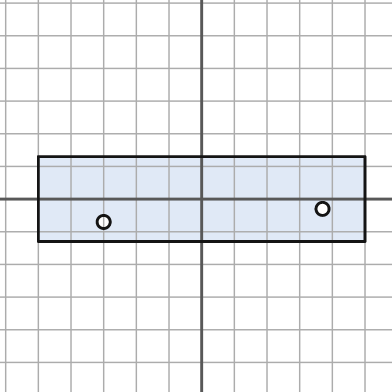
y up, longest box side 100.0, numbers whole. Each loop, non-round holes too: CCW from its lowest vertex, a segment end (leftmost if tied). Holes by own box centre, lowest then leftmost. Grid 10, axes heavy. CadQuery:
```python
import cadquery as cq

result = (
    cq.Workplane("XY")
    .moveTo(-50.0, -13.0)
    .lineTo(50.0, -13.0)
    .lineTo(50.0, 13.0)
    .lineTo(-50.0, 13.0)
    .close()
    .moveTo(-30.0, -7.0)
    .circle(2.0)
    .moveTo(37.0, -3.0)
    .circle(2.0)
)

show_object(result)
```